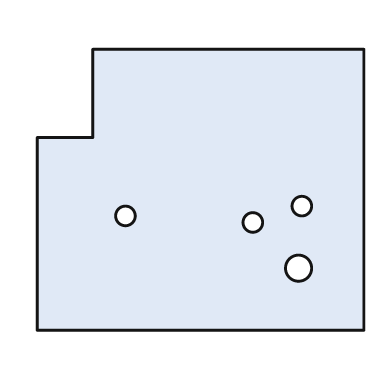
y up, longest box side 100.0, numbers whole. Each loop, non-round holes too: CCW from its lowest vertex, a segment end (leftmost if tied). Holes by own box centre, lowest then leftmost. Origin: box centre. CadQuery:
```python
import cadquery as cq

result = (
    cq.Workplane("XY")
    .moveTo(-50.0, -43.0)
    .lineTo(50.0, -43.0)
    .lineTo(50.0, 43.0)
    .lineTo(-33.0, 43.0)
    .lineTo(-33.0, 16.0)
    .lineTo(-50.0, 16.0)
    .close()
    .moveTo(30.0, -24.0)
    .circle(4.0)
    .moveTo(16.0, -10.0)
    .circle(3.0)
    .moveTo(-23.0, -8.0)
    .circle(3.0)
    .moveTo(31.0, -5.0)
    .circle(3.0)
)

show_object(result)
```